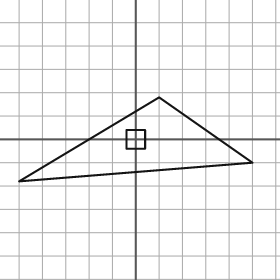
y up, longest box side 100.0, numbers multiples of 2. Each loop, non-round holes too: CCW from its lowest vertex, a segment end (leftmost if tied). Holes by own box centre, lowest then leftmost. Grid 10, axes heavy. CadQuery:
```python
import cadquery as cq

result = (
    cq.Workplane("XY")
    .moveTo(-50.0, -18.0)
    .lineTo(50.0, -10.0)
    .lineTo(10.0, 18.0)
    .close()
    .moveTo(-4.0, -4.0)
    .lineTo(4.0, -4.0)
    .lineTo(4.0, 4.0)
    .lineTo(-4.0, 4.0)
    .close()
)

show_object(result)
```